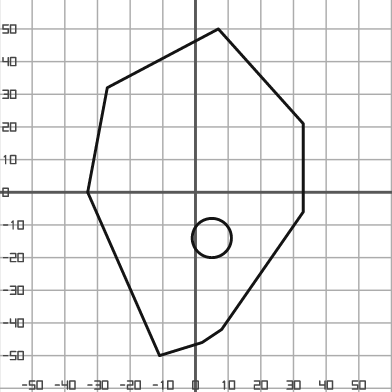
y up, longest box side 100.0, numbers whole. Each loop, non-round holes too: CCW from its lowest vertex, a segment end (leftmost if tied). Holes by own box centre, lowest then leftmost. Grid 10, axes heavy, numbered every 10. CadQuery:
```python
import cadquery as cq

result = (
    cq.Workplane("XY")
    .moveTo(-11.0, -50.0)
    .lineTo(2.0, -46.0)
    .lineTo(8.0, -42.0)
    .lineTo(33.0, -6.0)
    .lineTo(33.0, 21.0)
    .lineTo(7.0, 50.0)
    .lineTo(-27.0, 32.0)
    .lineTo(-33.0, 0.0)
    .close()
    .moveTo(5.0, -14.0)
    .circle(6.0)
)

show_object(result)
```